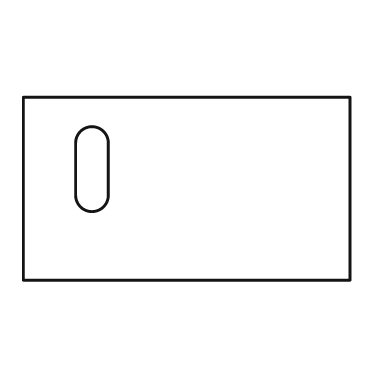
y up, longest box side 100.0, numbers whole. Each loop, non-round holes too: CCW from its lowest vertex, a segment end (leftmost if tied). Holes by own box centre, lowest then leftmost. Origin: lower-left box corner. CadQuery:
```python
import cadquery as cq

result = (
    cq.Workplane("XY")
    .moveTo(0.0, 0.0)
    .lineTo(100.0, 0.0)
    .lineTo(100.0, 56.0)
    .lineTo(0.0, 56.0)
    .close()
    .moveTo(16.0, 26.0)
    .threePointArc((21.0, 21.0), (26.0, 26.0))
    .lineTo(26.0, 42.0)
    .threePointArc((21.0, 47.0), (16.0, 42.0))
    .close()
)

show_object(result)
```